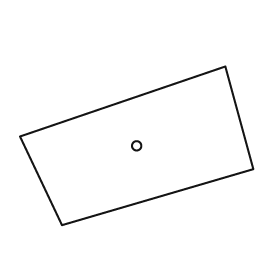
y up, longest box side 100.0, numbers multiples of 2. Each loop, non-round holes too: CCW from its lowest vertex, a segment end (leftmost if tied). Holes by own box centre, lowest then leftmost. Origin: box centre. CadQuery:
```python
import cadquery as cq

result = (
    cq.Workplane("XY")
    .moveTo(-32.0, -34.0)
    .lineTo(50.0, -10.0)
    .lineTo(38.0, 34.0)
    .lineTo(-50.0, 4.0)
    .close()
    .moveTo(0.0, 0.0)
    .circle(2.0)
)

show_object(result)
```